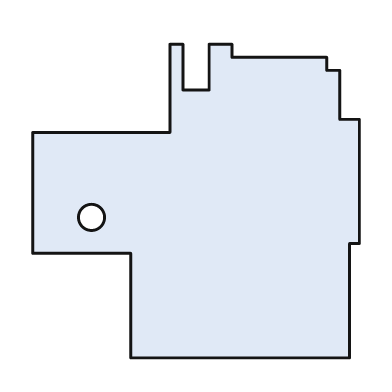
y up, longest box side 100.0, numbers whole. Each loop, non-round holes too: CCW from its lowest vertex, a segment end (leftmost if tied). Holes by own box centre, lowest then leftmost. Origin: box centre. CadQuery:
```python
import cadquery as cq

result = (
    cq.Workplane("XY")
    .moveTo(-20.0, -48.0)
    .lineTo(47.0, -48.0)
    .lineTo(47.0, -13.0)
    .lineTo(50.0, -13.0)
    .lineTo(50.0, 25.0)
    .lineTo(44.0, 25.0)
    .lineTo(44.0, 40.0)
    .lineTo(40.0, 40.0)
    .lineTo(40.0, 44.0)
    .lineTo(11.0, 44.0)
    .lineTo(11.0, 48.0)
    .lineTo(4.0, 48.0)
    .lineTo(4.0, 34.0)
    .lineTo(-4.0, 34.0)
    .lineTo(-4.0, 48.0)
    .lineTo(-8.0, 48.0)
    .lineTo(-8.0, 21.0)
    .lineTo(-50.0, 21.0)
    .lineTo(-50.0, -16.0)
    .lineTo(-20.0, -16.0)
    .close()
    .moveTo(-32.0, -5.0)
    .circle(4.0)
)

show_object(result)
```